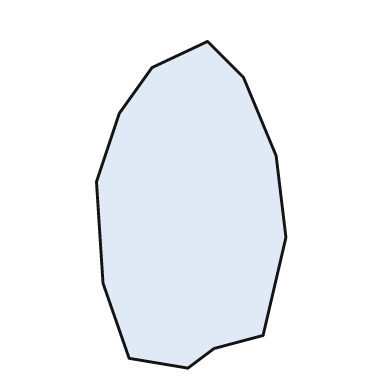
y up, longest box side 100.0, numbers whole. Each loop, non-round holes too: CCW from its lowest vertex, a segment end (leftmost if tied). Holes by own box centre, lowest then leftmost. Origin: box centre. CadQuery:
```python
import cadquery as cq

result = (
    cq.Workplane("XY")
    .moveTo(-1.0, -50.0)
    .lineTo(7.0, -44.0)
    .lineTo(22.0, -40.0)
    .lineTo(29.0, -10.0)
    .lineTo(26.0, 15.0)
    .lineTo(16.0, 39.0)
    .lineTo(5.0, 50.0)
    .lineTo(-12.0, 42.0)
    .lineTo(-22.0, 28.0)
    .lineTo(-29.0, 7.0)
    .lineTo(-27.0, -24.0)
    .lineTo(-19.0, -47.0)
    .close()
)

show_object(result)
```